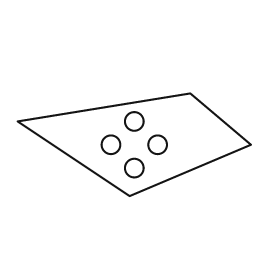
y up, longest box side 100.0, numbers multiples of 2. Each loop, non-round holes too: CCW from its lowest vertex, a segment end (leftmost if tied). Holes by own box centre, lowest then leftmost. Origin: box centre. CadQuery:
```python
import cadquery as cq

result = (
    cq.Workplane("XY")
    .moveTo(-2.0, -22.0)
    .lineTo(50.0, 0.0)
    .lineTo(24.0, 22.0)
    .lineTo(-50.0, 10.0)
    .close()
    .moveTo(0.0, -10.0)
    .circle(4.0)
    .moveTo(-10.0, 0.0)
    .circle(4.0)
    .moveTo(10.0, 0.0)
    .circle(4.0)
    .moveTo(0.0, 10.0)
    .circle(4.0)
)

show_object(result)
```